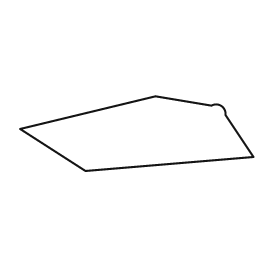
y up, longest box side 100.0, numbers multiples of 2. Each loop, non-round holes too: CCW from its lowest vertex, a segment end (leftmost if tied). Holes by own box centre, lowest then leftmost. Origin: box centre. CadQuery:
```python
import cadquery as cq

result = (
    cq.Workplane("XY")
    .moveTo(-22.0, -16.0)
    .lineTo(50.0, -10.0)
    .lineTo(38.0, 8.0)
    .threePointArc((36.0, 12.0), (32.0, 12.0))
    .lineTo(8.0, 16.0)
    .lineTo(-50.0, 2.0)
    .close()
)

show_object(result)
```